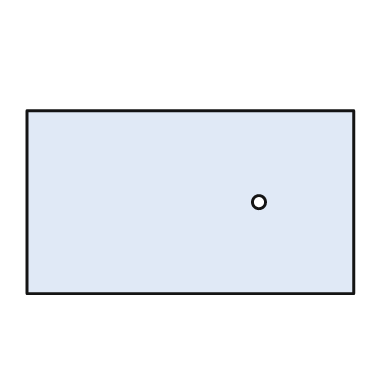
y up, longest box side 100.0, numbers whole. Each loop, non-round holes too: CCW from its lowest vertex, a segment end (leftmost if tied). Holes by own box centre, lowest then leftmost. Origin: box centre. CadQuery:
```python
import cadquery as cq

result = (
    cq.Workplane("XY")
    .moveTo(-50.0, -28.0)
    .lineTo(50.0, -28.0)
    .lineTo(50.0, 28.0)
    .lineTo(-50.0, 28.0)
    .close()
    .moveTo(21.0, 0.0)
    .circle(2.0)
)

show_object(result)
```